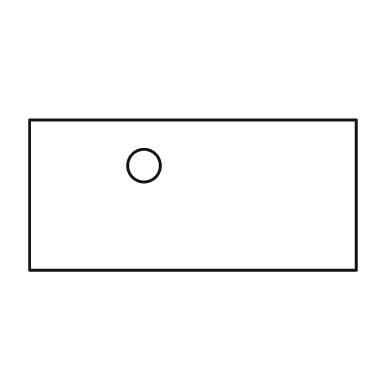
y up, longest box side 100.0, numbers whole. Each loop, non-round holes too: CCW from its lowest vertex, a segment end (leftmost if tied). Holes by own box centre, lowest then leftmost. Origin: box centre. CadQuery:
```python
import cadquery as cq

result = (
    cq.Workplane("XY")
    .moveTo(-50.0, -23.0)
    .lineTo(50.0, -23.0)
    .lineTo(50.0, 23.0)
    .lineTo(-50.0, 23.0)
    .close()
    .moveTo(-15.0, 9.0)
    .circle(5.0)
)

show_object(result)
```